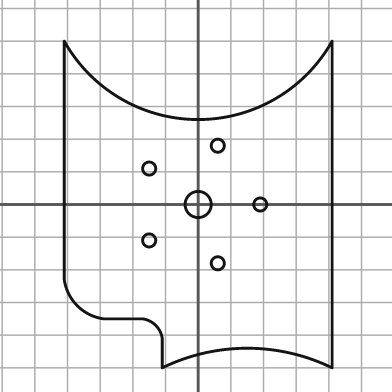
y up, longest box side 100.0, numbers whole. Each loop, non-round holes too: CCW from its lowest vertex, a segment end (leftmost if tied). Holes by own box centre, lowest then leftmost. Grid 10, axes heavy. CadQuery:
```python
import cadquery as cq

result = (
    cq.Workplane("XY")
    .moveTo(-11.0, -50.0)
    .threePointArc((15.0, -44.0), (41.0, -50.0))
    .lineTo(41.0, 50.0)
    .threePointArc((0.0, 26.0), (-41.0, 50.0))
    .lineTo(-41.0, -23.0)
    .threePointArc((-37.0, -31.0), (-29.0, -35.0))
    .lineTo(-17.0, -35.0)
    .threePointArc((-13.0, -37.0), (-11.0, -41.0))
    .close()
    .moveTo(6.0, -18.0)
    .circle(2.0)
    .moveTo(-15.0, -11.0)
    .circle(2.0)
    .moveTo(0.0, 0.0)
    .circle(4.0)
    .moveTo(19.0, 0.0)
    .circle(2.0)
    .moveTo(-15.0, 11.0)
    .circle(2.0)
    .moveTo(6.0, 18.0)
    .circle(2.0)
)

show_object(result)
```